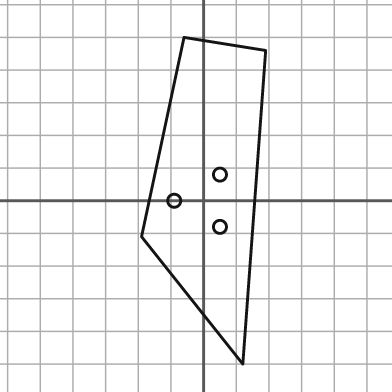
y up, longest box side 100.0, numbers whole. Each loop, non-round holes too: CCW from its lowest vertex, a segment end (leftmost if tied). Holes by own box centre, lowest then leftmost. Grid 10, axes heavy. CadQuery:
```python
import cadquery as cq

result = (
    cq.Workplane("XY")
    .moveTo(12.0, -50.0)
    .lineTo(19.0, 46.0)
    .lineTo(-6.0, 50.0)
    .lineTo(-19.0, -11.0)
    .close()
    .moveTo(5.0, -8.0)
    .circle(2.0)
    .moveTo(-9.0, 0.0)
    .circle(2.0)
    .moveTo(5.0, 8.0)
    .circle(2.0)
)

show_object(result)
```